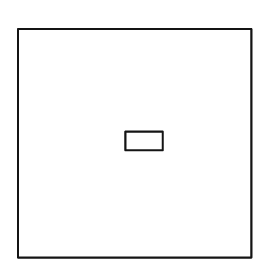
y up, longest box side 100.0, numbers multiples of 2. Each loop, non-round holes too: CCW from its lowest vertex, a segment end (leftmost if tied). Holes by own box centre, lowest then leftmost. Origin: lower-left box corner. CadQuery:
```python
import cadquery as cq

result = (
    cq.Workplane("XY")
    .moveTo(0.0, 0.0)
    .lineTo(100.0, 0.0)
    .lineTo(100.0, 98.0)
    .lineTo(0.0, 98.0)
    .close()
    .moveTo(46.0, 46.0)
    .lineTo(62.0, 46.0)
    .lineTo(62.0, 54.0)
    .lineTo(46.0, 54.0)
    .close()
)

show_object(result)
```